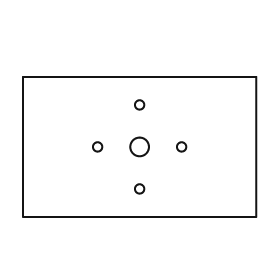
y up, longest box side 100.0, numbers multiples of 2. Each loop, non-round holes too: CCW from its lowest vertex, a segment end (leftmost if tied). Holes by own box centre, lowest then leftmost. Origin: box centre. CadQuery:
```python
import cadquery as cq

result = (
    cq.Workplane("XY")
    .moveTo(-50.0, -30.0)
    .lineTo(50.0, -30.0)
    .lineTo(50.0, 30.0)
    .lineTo(-50.0, 30.0)
    .close()
    .moveTo(0.0, -18.0)
    .circle(2.0)
    .moveTo(-18.0, 0.0)
    .circle(2.0)
    .moveTo(0.0, 0.0)
    .circle(4.0)
    .moveTo(18.0, 0.0)
    .circle(2.0)
    .moveTo(0.0, 18.0)
    .circle(2.0)
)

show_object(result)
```